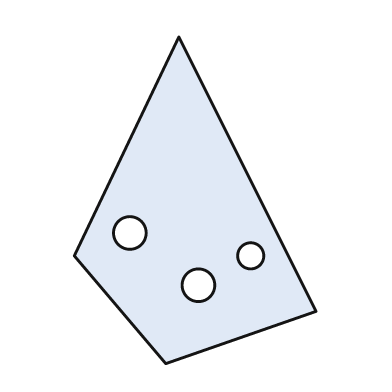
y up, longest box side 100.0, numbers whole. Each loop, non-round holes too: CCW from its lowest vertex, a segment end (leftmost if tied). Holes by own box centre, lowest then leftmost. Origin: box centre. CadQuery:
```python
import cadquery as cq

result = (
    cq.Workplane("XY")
    .moveTo(-9.0, -50.0)
    .lineTo(37.0, -34.0)
    .lineTo(-5.0, 50.0)
    .lineTo(-37.0, -17.0)
    .close()
    .moveTo(1.0, -26.0)
    .circle(5.0)
    .moveTo(17.0, -17.0)
    .circle(4.0)
    .moveTo(-20.0, -10.0)
    .circle(5.0)
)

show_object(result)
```